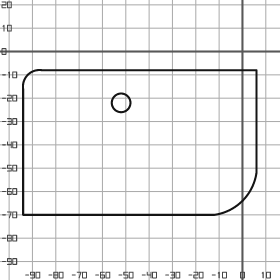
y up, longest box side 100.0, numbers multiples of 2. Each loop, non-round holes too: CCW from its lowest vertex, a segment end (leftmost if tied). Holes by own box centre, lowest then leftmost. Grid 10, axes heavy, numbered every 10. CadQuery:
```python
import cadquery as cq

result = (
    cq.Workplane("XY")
    .moveTo(-94.0, -70.0)
    .lineTo(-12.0, -70.0)
    .threePointArc((0.0, -64.0), (6.0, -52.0))
    .lineTo(6.0, -8.0)
    .lineTo(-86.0, -8.0)
    .threePointArc((-92.0, -10.0), (-94.0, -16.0))
    .close()
    .moveTo(-52.0, -22.0)
    .circle(4.0)
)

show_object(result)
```